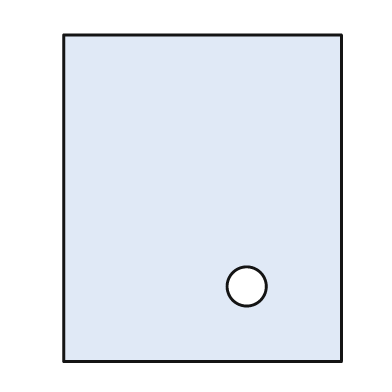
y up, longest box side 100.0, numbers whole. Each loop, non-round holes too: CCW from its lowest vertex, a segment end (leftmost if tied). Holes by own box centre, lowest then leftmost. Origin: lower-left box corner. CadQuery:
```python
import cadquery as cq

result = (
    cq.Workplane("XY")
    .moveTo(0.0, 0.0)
    .lineTo(85.0, 0.0)
    .lineTo(85.0, 100.0)
    .lineTo(0.0, 100.0)
    .close()
    .moveTo(56.0, 23.0)
    .circle(6.0)
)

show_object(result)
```